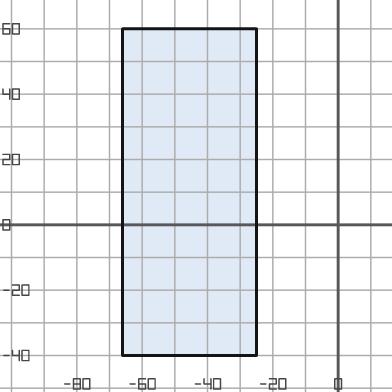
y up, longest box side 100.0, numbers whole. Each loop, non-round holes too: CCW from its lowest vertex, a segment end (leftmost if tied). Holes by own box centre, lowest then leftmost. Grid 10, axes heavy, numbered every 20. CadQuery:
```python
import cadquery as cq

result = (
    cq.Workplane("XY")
    .moveTo(-66.0, -40.0)
    .lineTo(-25.0, -40.0)
    .lineTo(-25.0, 60.0)
    .lineTo(-66.0, 60.0)
    .close()
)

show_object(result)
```